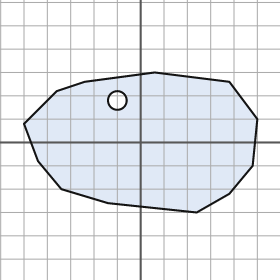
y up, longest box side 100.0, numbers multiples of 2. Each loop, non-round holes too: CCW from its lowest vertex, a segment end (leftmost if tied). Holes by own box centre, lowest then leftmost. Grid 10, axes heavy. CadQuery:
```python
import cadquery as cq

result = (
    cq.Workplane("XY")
    .moveTo(24.0, -30.0)
    .lineTo(38.0, -22.0)
    .lineTo(48.0, -10.0)
    .lineTo(50.0, 10.0)
    .lineTo(38.0, 26.0)
    .lineTo(6.0, 30.0)
    .lineTo(-24.0, 26.0)
    .lineTo(-36.0, 22.0)
    .lineTo(-50.0, 8.0)
    .lineTo(-44.0, -8.0)
    .lineTo(-34.0, -20.0)
    .lineTo(-14.0, -26.0)
    .close()
    .moveTo(-10.0, 18.0)
    .circle(4.0)
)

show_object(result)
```